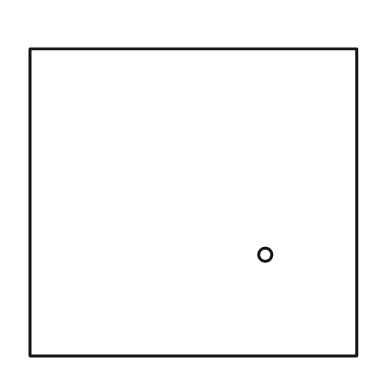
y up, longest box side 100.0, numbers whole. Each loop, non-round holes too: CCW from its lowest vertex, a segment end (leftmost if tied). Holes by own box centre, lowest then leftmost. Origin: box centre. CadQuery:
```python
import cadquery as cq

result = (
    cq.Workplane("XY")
    .moveTo(-50.0, -47.0)
    .lineTo(50.0, -47.0)
    .lineTo(50.0, 47.0)
    .lineTo(-50.0, 47.0)
    .close()
    .moveTo(22.0, -16.0)
    .circle(2.0)
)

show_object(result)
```